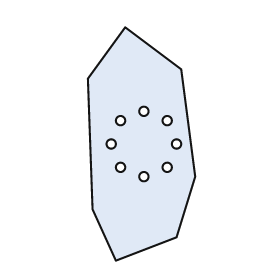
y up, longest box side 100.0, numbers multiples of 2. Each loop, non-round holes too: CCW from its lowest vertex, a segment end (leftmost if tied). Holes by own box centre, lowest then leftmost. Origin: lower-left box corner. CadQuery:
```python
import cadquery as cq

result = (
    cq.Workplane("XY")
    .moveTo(12.0, 0.0)
    .lineTo(38.0, 10.0)
    .lineTo(46.0, 36.0)
    .lineTo(40.0, 82.0)
    .lineTo(16.0, 100.0)
    .lineTo(0.0, 78.0)
    .lineTo(2.0, 22.0)
    .close()
    .moveTo(24.0, 36.0)
    .circle(2.0)
    .moveTo(14.0, 40.0)
    .circle(2.0)
    .moveTo(34.0, 40.0)
    .circle(2.0)
    .moveTo(10.0, 50.0)
    .circle(2.0)
    .moveTo(38.0, 50.0)
    .circle(2.0)
    .moveTo(14.0, 60.0)
    .circle(2.0)
    .moveTo(34.0, 60.0)
    .circle(2.0)
    .moveTo(24.0, 64.0)
    .circle(2.0)
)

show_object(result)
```